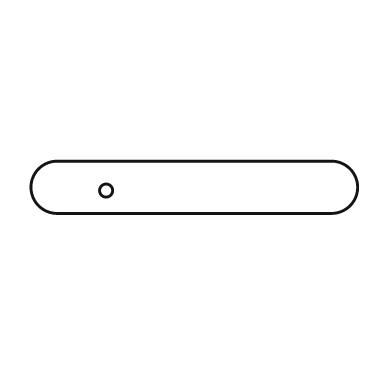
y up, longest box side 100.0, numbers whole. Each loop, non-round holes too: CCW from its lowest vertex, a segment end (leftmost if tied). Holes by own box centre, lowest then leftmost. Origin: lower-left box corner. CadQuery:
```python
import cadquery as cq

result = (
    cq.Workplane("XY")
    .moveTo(8.0, 0.0)
    .lineTo(92.0, 0.0)
    .threePointArc((100.0, 8.0), (92.0, 16.0))
    .lineTo(8.0, 16.0)
    .threePointArc((0.0, 8.0), (8.0, 0.0))
    .close()
    .moveTo(23.0, 7.0)
    .circle(2.0)
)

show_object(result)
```